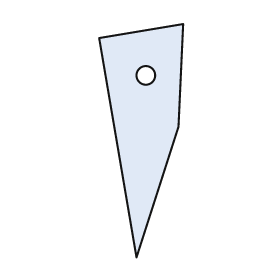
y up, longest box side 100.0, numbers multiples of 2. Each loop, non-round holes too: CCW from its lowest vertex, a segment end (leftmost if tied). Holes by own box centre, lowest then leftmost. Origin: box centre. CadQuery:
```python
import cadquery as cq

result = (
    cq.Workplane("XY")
    .moveTo(-2.0, -50.0)
    .lineTo(16.0, 6.0)
    .lineTo(18.0, 50.0)
    .lineTo(-18.0, 44.0)
    .close()
    .moveTo(2.0, 28.0)
    .circle(4.0)
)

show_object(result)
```